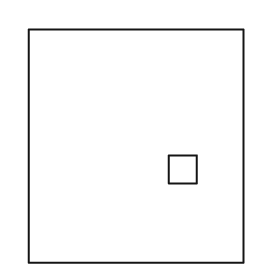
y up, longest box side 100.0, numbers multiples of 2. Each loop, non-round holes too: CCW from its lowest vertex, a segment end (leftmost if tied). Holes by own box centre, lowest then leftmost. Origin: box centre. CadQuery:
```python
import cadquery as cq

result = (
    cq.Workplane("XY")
    .moveTo(-46.0, -50.0)
    .lineTo(46.0, -50.0)
    .lineTo(46.0, 50.0)
    .lineTo(-46.0, 50.0)
    .close()
    .moveTo(14.0, -16.0)
    .lineTo(26.0, -16.0)
    .lineTo(26.0, -4.0)
    .lineTo(14.0, -4.0)
    .close()
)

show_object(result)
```